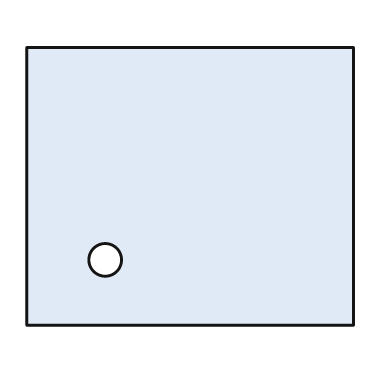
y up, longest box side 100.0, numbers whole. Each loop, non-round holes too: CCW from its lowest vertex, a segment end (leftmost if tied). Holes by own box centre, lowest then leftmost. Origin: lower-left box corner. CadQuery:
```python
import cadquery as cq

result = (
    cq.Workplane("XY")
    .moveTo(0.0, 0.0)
    .lineTo(100.0, 0.0)
    .lineTo(100.0, 85.0)
    .lineTo(0.0, 85.0)
    .close()
    .moveTo(24.0, 20.0)
    .circle(5.0)
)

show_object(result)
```